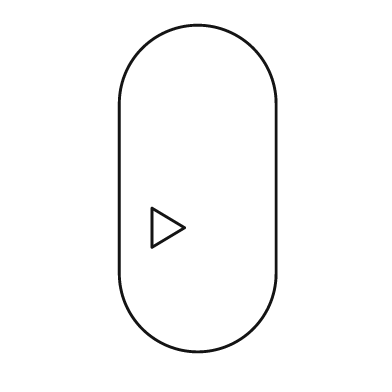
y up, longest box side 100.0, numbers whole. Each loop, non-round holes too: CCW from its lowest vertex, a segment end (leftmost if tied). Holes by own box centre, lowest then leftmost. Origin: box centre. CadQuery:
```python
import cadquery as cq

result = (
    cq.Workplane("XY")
    .moveTo(-24.0, -26.0)
    .threePointArc((0.0, -50.0), (24.0, -26.0))
    .lineTo(24.0, 26.0)
    .threePointArc((0.0, 50.0), (-24.0, 26.0))
    .close()
    .moveTo(-14.0, -18.0)
    .lineTo(-4.0, -12.0)
    .lineTo(-14.0, -6.0)
    .close()
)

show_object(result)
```